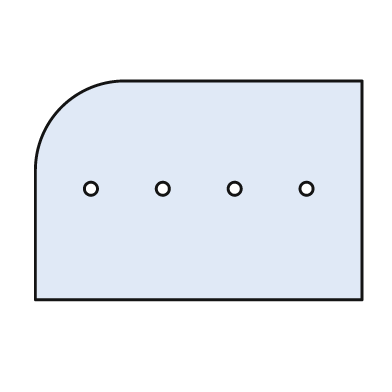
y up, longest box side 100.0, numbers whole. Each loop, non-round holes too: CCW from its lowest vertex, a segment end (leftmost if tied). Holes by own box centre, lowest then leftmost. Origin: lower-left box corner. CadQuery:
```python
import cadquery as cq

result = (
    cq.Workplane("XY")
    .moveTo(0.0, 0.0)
    .lineTo(100.0, 0.0)
    .lineTo(100.0, 67.0)
    .lineTo(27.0, 67.0)
    .threePointArc((8.0, 59.0), (0.0, 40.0))
    .close()
    .moveTo(17.0, 34.0)
    .circle(2.0)
    .moveTo(39.0, 34.0)
    .circle(2.0)
    .moveTo(61.0, 34.0)
    .circle(2.0)
    .moveTo(83.0, 34.0)
    .circle(2.0)
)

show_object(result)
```